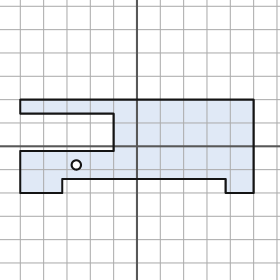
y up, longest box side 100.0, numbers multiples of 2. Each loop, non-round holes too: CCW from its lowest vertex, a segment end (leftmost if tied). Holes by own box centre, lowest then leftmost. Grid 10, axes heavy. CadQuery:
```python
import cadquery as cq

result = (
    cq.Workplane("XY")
    .moveTo(-50.0, -20.0)
    .lineTo(-32.0, -20.0)
    .lineTo(-32.0, -14.0)
    .lineTo(38.0, -14.0)
    .lineTo(38.0, -20.0)
    .lineTo(50.0, -20.0)
    .lineTo(50.0, 20.0)
    .lineTo(-50.0, 20.0)
    .lineTo(-50.0, 14.0)
    .lineTo(-10.0, 14.0)
    .lineTo(-10.0, -2.0)
    .lineTo(-50.0, -2.0)
    .close()
    .moveTo(-26.0, -8.0)
    .circle(2.0)
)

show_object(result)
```